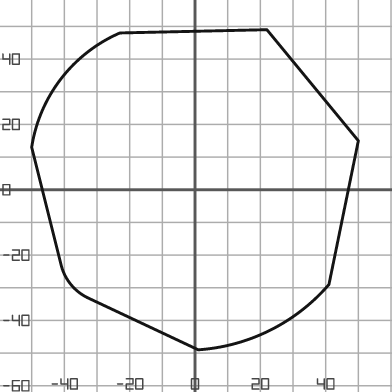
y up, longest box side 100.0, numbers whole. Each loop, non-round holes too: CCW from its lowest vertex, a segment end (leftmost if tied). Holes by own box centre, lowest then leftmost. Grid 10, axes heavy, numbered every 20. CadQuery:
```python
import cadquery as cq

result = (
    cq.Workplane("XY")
    .moveTo(1.0, -49.0)
    .threePointArc((23.0, -43.0), (41.0, -29.0))
    .lineTo(50.0, 15.0)
    .lineTo(22.0, 49.0)
    .lineTo(-23.0, 48.0)
    .threePointArc((-41.0, 34.0), (-50.0, 13.0))
    .lineTo(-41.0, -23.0)
    .threePointArc((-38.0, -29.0), (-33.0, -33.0))
    .close()
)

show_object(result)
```